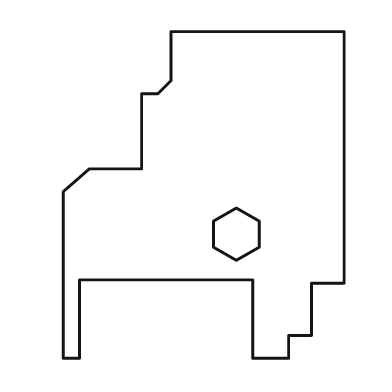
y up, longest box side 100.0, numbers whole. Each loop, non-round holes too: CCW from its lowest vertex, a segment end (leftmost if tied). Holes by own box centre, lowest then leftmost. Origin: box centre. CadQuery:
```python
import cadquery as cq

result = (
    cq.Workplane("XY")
    .moveTo(-43.0, -50.0)
    .lineTo(-38.0, -50.0)
    .lineTo(-38.0, -26.0)
    .lineTo(15.0, -26.0)
    .lineTo(15.0, -50.0)
    .lineTo(26.0, -50.0)
    .lineTo(26.0, -43.0)
    .lineTo(33.0, -43.0)
    .lineTo(33.0, -27.0)
    .lineTo(43.0, -27.0)
    .lineTo(43.0, 50.0)
    .lineTo(-10.0, 50.0)
    .lineTo(-10.0, 35.0)
    .lineTo(-14.0, 31.0)
    .lineTo(-19.0, 31.0)
    .lineTo(-19.0, 8.0)
    .lineTo(-35.0, 8.0)
    .lineTo(-43.0, 1.0)
    .close()
    .moveTo(10.0, -20.0)
    .lineTo(17.0, -16.0)
    .lineTo(17.0, -8.0)
    .lineTo(10.0, -4.0)
    .lineTo(3.0, -8.0)
    .lineTo(3.0, -16.0)
    .close()
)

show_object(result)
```